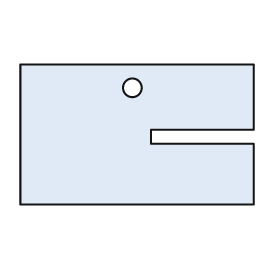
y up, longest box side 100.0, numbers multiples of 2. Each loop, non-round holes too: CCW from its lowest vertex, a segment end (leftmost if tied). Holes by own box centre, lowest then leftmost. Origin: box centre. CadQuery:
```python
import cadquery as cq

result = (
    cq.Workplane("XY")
    .moveTo(-50.0, -30.0)
    .lineTo(50.0, -30.0)
    .lineTo(50.0, -4.0)
    .lineTo(6.0, -4.0)
    .lineTo(6.0, 2.0)
    .lineTo(50.0, 2.0)
    .lineTo(50.0, 30.0)
    .lineTo(-50.0, 30.0)
    .close()
    .moveTo(-2.0, 20.0)
    .circle(4.0)
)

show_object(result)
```